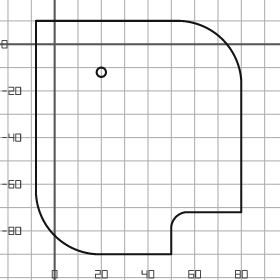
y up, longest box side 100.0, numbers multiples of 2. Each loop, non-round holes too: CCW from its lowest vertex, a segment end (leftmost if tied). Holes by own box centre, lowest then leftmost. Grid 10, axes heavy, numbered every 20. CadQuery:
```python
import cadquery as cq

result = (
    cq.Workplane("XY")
    .moveTo(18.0, -90.0)
    .lineTo(50.0, -90.0)
    .lineTo(50.0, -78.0)
    .threePointArc((52.0, -74.0), (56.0, -72.0))
    .lineTo(80.0, -72.0)
    .lineTo(80.0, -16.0)
    .threePointArc((72.0, 2.0), (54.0, 10.0))
    .lineTo(-8.0, 10.0)
    .lineTo(-8.0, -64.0)
    .threePointArc((0.0, -82.0), (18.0, -90.0))
    .close()
    .moveTo(20.0, -12.0)
    .circle(2.0)
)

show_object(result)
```